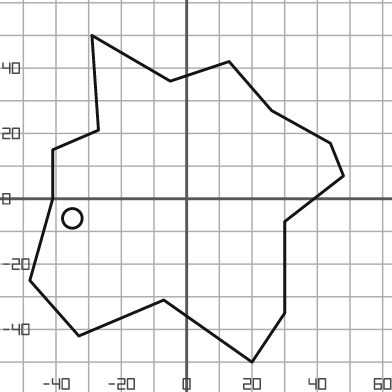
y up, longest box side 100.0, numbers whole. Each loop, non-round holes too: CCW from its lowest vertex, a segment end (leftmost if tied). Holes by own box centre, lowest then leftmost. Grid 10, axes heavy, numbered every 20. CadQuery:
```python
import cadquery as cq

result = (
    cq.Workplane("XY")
    .moveTo(20.0, -50.0)
    .lineTo(30.0, -35.0)
    .lineTo(30.0, -7.0)
    .lineTo(48.0, 7.0)
    .lineTo(44.0, 17.0)
    .lineTo(26.0, 27.0)
    .lineTo(13.0, 42.0)
    .lineTo(-5.0, 36.0)
    .lineTo(-29.0, 50.0)
    .lineTo(-27.0, 21.0)
    .lineTo(-41.0, 15.0)
    .lineTo(-41.0, 0.0)
    .lineTo(-48.0, -25.0)
    .lineTo(-33.0, -42.0)
    .lineTo(-7.0, -31.0)
    .close()
    .moveTo(-35.0, -6.0)
    .circle(3.0)
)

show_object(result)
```